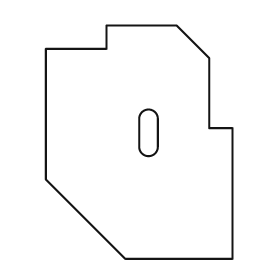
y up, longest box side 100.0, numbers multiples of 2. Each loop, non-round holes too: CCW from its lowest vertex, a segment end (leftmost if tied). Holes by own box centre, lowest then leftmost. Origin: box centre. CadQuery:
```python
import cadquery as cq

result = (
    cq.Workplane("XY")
    .moveTo(-6.0, -50.0)
    .lineTo(40.0, -50.0)
    .lineTo(40.0, 6.0)
    .lineTo(30.0, 6.0)
    .lineTo(30.0, 36.0)
    .lineTo(16.0, 50.0)
    .lineTo(-14.0, 50.0)
    .lineTo(-14.0, 40.0)
    .lineTo(-40.0, 40.0)
    .lineTo(-40.0, -16.0)
    .close()
    .moveTo(0.0, -2.0)
    .threePointArc((4.0, -6.0), (8.0, -2.0))
    .lineTo(8.0, 10.0)
    .threePointArc((4.0, 14.0), (0.0, 10.0))
    .close()
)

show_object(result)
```